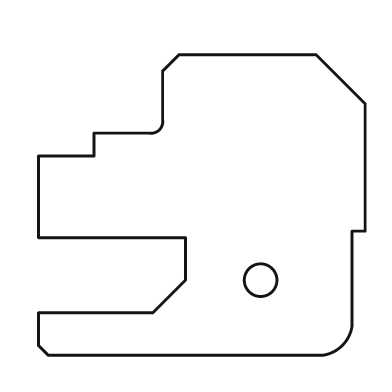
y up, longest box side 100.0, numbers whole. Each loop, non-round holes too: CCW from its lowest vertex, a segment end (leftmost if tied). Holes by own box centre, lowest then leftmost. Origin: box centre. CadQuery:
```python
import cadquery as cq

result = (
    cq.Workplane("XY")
    .moveTo(-47.0, -46.0)
    .lineTo(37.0, -46.0)
    .threePointArc((43.0, -43.0), (46.0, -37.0))
    .lineTo(46.0, -8.0)
    .lineTo(50.0, -8.0)
    .lineTo(50.0, 31.0)
    .lineTo(35.0, 46.0)
    .lineTo(-7.0, 46.0)
    .lineTo(-12.0, 41.0)
    .lineTo(-12.0, 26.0)
    .threePointArc((-13.0, 23.0), (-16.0, 22.0))
    .lineTo(-33.0, 22.0)
    .lineTo(-33.0, 15.0)
    .lineTo(-50.0, 15.0)
    .lineTo(-50.0, -10.0)
    .lineTo(-5.0, -10.0)
    .lineTo(-5.0, -23.0)
    .lineTo(-15.0, -33.0)
    .lineTo(-50.0, -33.0)
    .lineTo(-50.0, -43.0)
    .close()
    .moveTo(18.0, -23.0)
    .circle(5.0)
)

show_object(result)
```